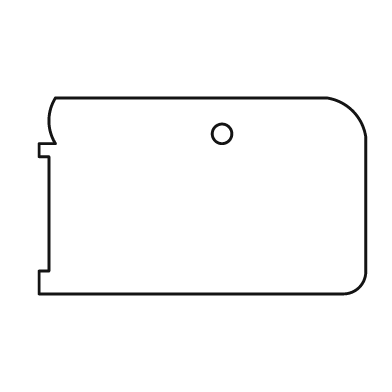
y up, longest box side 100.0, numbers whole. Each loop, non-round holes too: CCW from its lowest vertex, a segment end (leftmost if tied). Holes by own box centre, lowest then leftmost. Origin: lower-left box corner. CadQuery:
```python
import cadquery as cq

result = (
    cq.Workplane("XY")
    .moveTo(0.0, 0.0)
    .lineTo(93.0, 0.0)
    .threePointArc((98.0, 2.0), (100.0, 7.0))
    .lineTo(100.0, 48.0)
    .threePointArc((96.0, 56.0), (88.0, 60.0))
    .lineTo(5.0, 60.0)
    .threePointArc((3.0, 53.0), (5.0, 46.0))
    .lineTo(0.0, 46.0)
    .lineTo(0.0, 42.0)
    .lineTo(3.0, 42.0)
    .lineTo(3.0, 7.0)
    .lineTo(0.0, 7.0)
    .close()
    .moveTo(56.0, 49.0)
    .circle(3.0)
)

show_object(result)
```